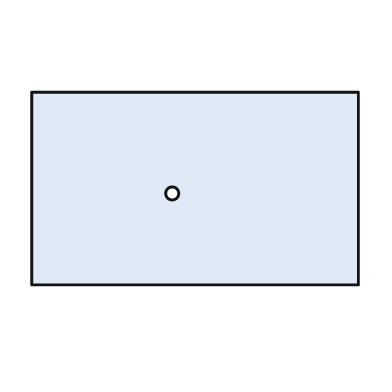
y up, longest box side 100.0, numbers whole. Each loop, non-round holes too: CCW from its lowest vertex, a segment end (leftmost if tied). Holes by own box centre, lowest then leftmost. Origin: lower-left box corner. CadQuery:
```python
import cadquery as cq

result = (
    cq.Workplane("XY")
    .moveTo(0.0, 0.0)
    .lineTo(100.0, 0.0)
    .lineTo(100.0, 59.0)
    .lineTo(0.0, 59.0)
    .close()
    .moveTo(43.0, 28.0)
    .circle(2.0)
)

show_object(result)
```